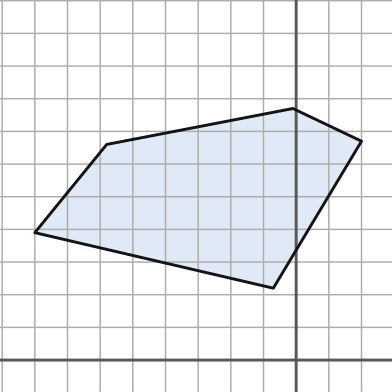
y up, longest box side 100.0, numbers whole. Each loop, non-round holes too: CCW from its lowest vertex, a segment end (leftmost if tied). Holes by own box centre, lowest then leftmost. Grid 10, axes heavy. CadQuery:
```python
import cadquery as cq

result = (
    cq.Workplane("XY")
    .moveTo(-7.0, 22.0)
    .lineTo(20.0, 67.0)
    .lineTo(-1.0, 77.0)
    .lineTo(-58.0, 66.0)
    .lineTo(-80.0, 39.0)
    .close()
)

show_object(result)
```